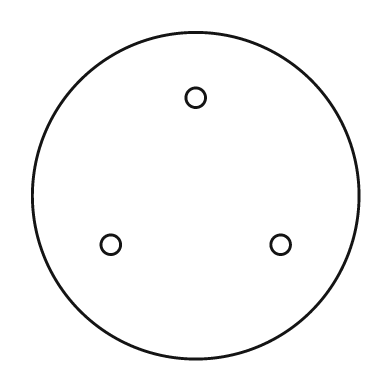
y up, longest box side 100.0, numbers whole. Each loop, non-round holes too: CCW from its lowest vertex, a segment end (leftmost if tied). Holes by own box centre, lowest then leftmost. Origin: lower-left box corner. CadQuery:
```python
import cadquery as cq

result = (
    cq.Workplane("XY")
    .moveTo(50.0, 50.0)
    .circle(50.0)
    .moveTo(24.0, 35.0)
    .circle(3.0)
    .moveTo(76.0, 35.0)
    .circle(3.0)
    .moveTo(50.0, 80.0)
    .circle(3.0)
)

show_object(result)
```